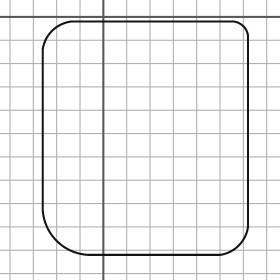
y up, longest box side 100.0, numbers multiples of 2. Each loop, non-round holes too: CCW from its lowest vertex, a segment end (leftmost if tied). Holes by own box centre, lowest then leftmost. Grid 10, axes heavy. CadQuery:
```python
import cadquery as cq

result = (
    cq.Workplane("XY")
    .moveTo(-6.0, -102.0)
    .lineTo(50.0, -102.0)
    .threePointArc((58.0, -98.0), (62.0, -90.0))
    .lineTo(62.0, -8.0)
    .threePointArc((60.0, -4.0), (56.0, -2.0))
    .lineTo(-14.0, -2.0)
    .threePointArc((-22.0, -6.0), (-26.0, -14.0))
    .lineTo(-26.0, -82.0)
    .threePointArc((-20.0, -96.0), (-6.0, -102.0))
    .close()
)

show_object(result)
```